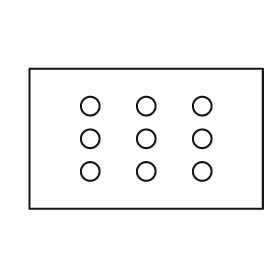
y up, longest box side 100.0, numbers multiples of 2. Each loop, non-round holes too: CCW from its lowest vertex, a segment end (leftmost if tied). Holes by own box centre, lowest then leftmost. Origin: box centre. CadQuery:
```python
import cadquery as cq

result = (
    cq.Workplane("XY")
    .moveTo(-50.0, -30.0)
    .lineTo(50.0, -30.0)
    .lineTo(50.0, 30.0)
    .lineTo(-50.0, 30.0)
    .close()
    .moveTo(-24.0, -14.0)
    .circle(4.0)
    .moveTo(0.0, -14.0)
    .circle(4.0)
    .moveTo(24.0, -14.0)
    .circle(4.0)
    .moveTo(-24.0, 0.0)
    .circle(4.0)
    .moveTo(0.0, 0.0)
    .circle(4.0)
    .moveTo(24.0, 0.0)
    .circle(4.0)
    .moveTo(-24.0, 14.0)
    .circle(4.0)
    .moveTo(0.0, 14.0)
    .circle(4.0)
    .moveTo(24.0, 14.0)
    .circle(4.0)
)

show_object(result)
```